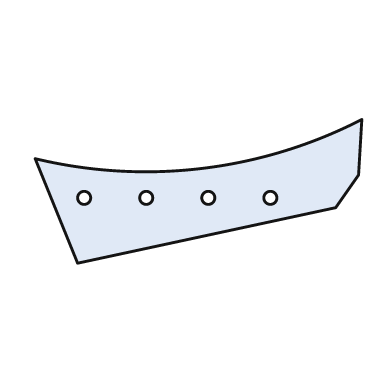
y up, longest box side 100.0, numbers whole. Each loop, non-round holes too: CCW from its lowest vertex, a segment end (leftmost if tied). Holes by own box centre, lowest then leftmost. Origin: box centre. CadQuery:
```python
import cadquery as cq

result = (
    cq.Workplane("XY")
    .moveTo(-37.0, -22.0)
    .lineTo(42.0, -5.0)
    .lineTo(49.0, 5.0)
    .lineTo(50.0, 22.0)
    .threePointArc((1.0, 7.0), (-50.0, 10.0))
    .close()
    .moveTo(-35.0, -2.0)
    .circle(2.0)
    .moveTo(-16.0, -2.0)
    .circle(2.0)
    .moveTo(3.0, -2.0)
    .circle(2.0)
    .moveTo(22.0, -2.0)
    .circle(2.0)
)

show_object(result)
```